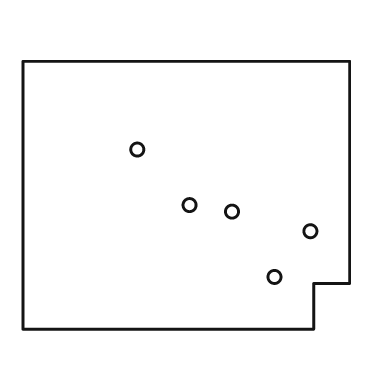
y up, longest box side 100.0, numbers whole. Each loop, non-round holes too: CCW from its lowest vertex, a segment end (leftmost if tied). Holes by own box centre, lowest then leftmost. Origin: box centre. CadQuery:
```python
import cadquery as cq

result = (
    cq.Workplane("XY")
    .moveTo(-50.0, -41.0)
    .lineTo(39.0, -41.0)
    .lineTo(39.0, -27.0)
    .lineTo(50.0, -27.0)
    .lineTo(50.0, 41.0)
    .lineTo(-50.0, 41.0)
    .close()
    .moveTo(27.0, -25.0)
    .circle(2.0)
    .moveTo(38.0, -11.0)
    .circle(2.0)
    .moveTo(14.0, -5.0)
    .circle(2.0)
    .moveTo(1.0, -3.0)
    .circle(2.0)
    .moveTo(-15.0, 14.0)
    .circle(2.0)
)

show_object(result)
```